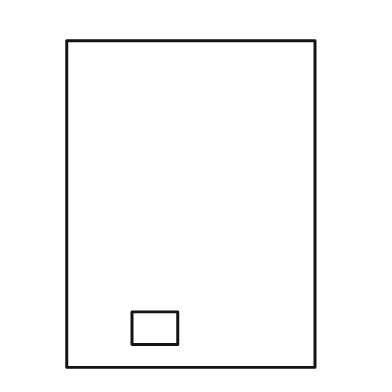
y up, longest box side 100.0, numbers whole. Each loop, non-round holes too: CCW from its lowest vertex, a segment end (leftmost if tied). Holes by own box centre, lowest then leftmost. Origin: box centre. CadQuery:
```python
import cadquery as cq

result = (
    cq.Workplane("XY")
    .moveTo(-38.0, -50.0)
    .lineTo(38.0, -50.0)
    .lineTo(38.0, 50.0)
    .lineTo(-38.0, 50.0)
    .close()
    .moveTo(-18.0, -43.0)
    .lineTo(-4.0, -43.0)
    .lineTo(-4.0, -33.0)
    .lineTo(-18.0, -33.0)
    .close()
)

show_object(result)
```